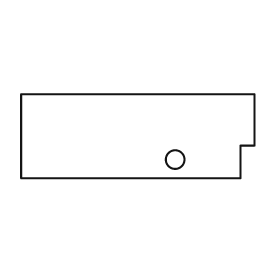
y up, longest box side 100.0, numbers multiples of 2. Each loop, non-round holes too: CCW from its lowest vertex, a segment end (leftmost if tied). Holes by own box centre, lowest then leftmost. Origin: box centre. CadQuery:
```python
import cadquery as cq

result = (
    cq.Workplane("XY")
    .moveTo(-50.0, -18.0)
    .lineTo(44.0, -18.0)
    .lineTo(44.0, -4.0)
    .lineTo(50.0, -4.0)
    .lineTo(50.0, 18.0)
    .lineTo(-50.0, 18.0)
    .close()
    .moveTo(16.0, -10.0)
    .circle(4.0)
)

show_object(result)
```